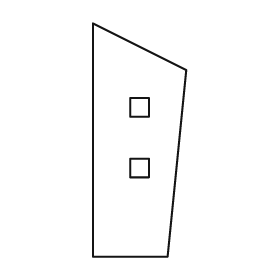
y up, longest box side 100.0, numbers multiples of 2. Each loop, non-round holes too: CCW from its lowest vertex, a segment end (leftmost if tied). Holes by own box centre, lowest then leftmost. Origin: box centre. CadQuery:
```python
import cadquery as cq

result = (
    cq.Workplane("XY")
    .moveTo(-20.0, -50.0)
    .lineTo(12.0, -50.0)
    .lineTo(20.0, 30.0)
    .lineTo(-20.0, 50.0)
    .close()
    .moveTo(-4.0, -16.0)
    .lineTo(4.0, -16.0)
    .lineTo(4.0, -8.0)
    .lineTo(-4.0, -8.0)
    .close()
    .moveTo(-4.0, 10.0)
    .lineTo(4.0, 10.0)
    .lineTo(4.0, 18.0)
    .lineTo(-4.0, 18.0)
    .close()
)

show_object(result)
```